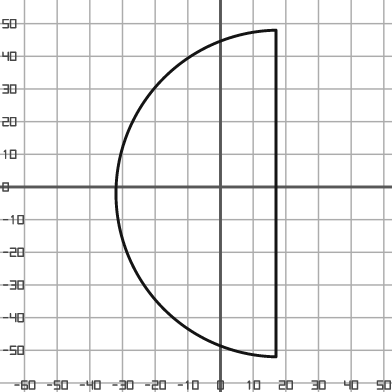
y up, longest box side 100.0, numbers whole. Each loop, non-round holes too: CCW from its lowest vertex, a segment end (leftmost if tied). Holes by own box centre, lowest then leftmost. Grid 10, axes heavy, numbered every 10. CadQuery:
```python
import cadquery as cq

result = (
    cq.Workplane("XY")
    .moveTo(17.0, -52.0)
    .lineTo(17.0, 48.0)
    .threePointArc((-32.0, -2.0), (17.0, -52.0))
    .close()
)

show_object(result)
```